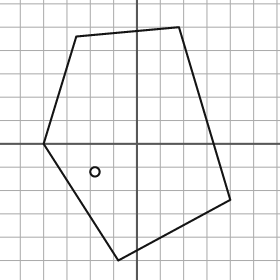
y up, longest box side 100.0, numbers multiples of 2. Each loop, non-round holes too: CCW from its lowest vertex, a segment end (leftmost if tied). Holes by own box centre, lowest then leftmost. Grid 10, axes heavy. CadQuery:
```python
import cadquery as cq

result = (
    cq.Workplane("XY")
    .moveTo(-8.0, -50.0)
    .lineTo(40.0, -24.0)
    .lineTo(18.0, 50.0)
    .lineTo(-26.0, 46.0)
    .lineTo(-40.0, 0.0)
    .close()
    .moveTo(-18.0, -12.0)
    .circle(2.0)
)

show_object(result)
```